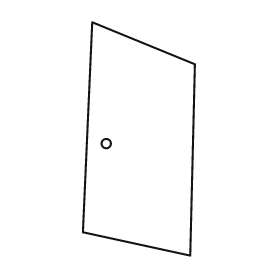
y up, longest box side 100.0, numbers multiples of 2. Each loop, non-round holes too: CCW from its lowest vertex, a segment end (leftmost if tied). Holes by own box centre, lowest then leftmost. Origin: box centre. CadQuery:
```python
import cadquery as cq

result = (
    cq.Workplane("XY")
    .moveTo(22.0, -50.0)
    .lineTo(24.0, 32.0)
    .lineTo(-20.0, 50.0)
    .lineTo(-24.0, -40.0)
    .close()
    .moveTo(-14.0, -2.0)
    .circle(2.0)
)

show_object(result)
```